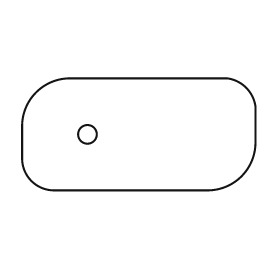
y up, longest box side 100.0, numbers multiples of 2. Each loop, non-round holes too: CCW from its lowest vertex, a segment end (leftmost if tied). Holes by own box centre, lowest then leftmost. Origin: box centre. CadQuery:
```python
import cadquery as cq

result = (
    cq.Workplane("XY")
    .moveTo(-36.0, -24.0)
    .lineTo(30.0, -24.0)
    .threePointArc((44.0, -18.0), (50.0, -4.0))
    .lineTo(50.0, 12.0)
    .threePointArc((46.0, 20.0), (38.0, 24.0))
    .lineTo(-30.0, 24.0)
    .threePointArc((-44.0, 18.0), (-50.0, 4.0))
    .lineTo(-50.0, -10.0)
    .threePointArc((-46.0, -20.0), (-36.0, -24.0))
    .close()
    .moveTo(-22.0, 0.0)
    .circle(4.0)
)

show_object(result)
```